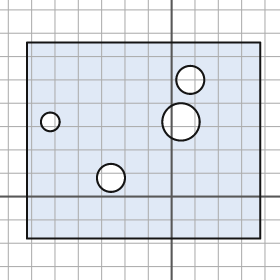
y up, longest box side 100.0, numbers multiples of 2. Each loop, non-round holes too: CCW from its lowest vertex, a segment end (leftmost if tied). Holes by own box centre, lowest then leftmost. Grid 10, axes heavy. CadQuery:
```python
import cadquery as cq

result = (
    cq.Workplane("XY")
    .moveTo(-62.0, -18.0)
    .lineTo(38.0, -18.0)
    .lineTo(38.0, 66.0)
    .lineTo(-62.0, 66.0)
    .close()
    .moveTo(-26.0, 8.0)
    .circle(6.0)
    .moveTo(-52.0, 32.0)
    .circle(4.0)
    .moveTo(4.0, 32.0)
    .circle(8.0)
    .moveTo(8.0, 50.0)
    .circle(6.0)
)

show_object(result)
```